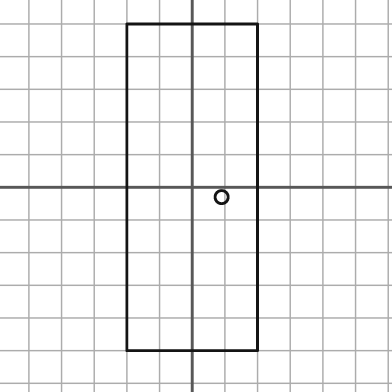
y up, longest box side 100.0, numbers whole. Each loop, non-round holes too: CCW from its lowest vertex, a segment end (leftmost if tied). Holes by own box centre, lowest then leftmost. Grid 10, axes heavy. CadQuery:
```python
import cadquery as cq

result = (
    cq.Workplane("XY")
    .moveTo(-20.0, -50.0)
    .lineTo(20.0, -50.0)
    .lineTo(20.0, 50.0)
    .lineTo(-20.0, 50.0)
    .close()
    .moveTo(9.0, -3.0)
    .circle(2.0)
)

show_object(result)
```